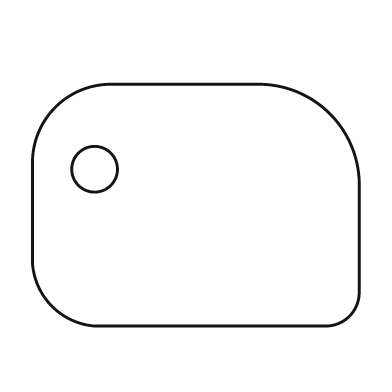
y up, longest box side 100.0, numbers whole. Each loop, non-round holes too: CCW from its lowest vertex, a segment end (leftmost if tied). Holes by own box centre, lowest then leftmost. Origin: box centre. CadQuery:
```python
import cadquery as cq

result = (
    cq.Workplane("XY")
    .moveTo(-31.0, -37.0)
    .lineTo(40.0, -37.0)
    .threePointArc((47.0, -34.0), (50.0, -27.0))
    .lineTo(50.0, 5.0)
    .threePointArc((41.0, 28.0), (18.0, 37.0))
    .lineTo(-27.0, 37.0)
    .threePointArc((-43.0, 30.0), (-50.0, 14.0))
    .lineTo(-50.0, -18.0)
    .threePointArc((-44.0, -31.0), (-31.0, -37.0))
    .close()
    .moveTo(-31.0, 11.0)
    .circle(7.0)
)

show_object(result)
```